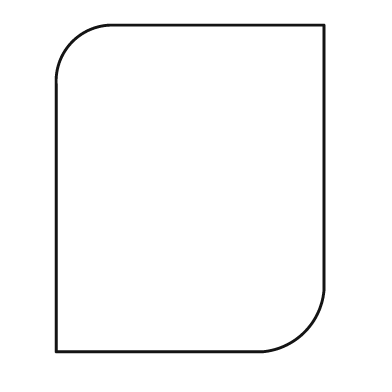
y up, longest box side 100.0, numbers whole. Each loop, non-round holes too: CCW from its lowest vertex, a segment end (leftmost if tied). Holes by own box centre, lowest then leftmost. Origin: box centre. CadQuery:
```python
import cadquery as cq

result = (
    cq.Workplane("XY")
    .moveTo(-41.0, -50.0)
    .lineTo(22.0, -50.0)
    .threePointArc((35.0, -44.0), (41.0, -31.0))
    .lineTo(41.0, 50.0)
    .lineTo(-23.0, 50.0)
    .threePointArc((-36.0, 45.0), (-41.0, 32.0))
    .close()
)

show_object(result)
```